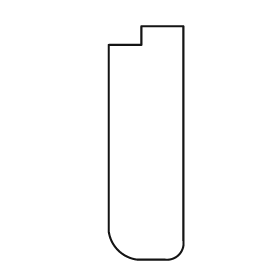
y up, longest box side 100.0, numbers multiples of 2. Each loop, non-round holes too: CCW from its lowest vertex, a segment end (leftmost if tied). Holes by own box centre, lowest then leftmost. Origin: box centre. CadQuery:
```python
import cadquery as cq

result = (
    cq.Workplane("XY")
    .moveTo(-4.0, -50.0)
    .lineTo(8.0, -50.0)
    .threePointArc((14.0, -48.0), (16.0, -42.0))
    .lineTo(16.0, 50.0)
    .lineTo(-2.0, 50.0)
    .lineTo(-2.0, 42.0)
    .lineTo(-16.0, 42.0)
    .lineTo(-16.0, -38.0)
    .threePointArc((-12.0, -46.0), (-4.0, -50.0))
    .close()
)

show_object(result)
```